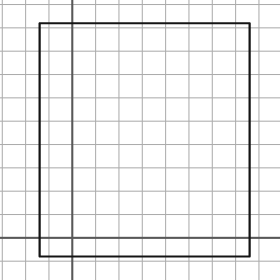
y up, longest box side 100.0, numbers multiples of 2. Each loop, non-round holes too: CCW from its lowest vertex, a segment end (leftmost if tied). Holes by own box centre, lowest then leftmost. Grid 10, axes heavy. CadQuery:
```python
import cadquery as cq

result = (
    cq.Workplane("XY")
    .moveTo(-14.0, -8.0)
    .lineTo(76.0, -8.0)
    .lineTo(76.0, 92.0)
    .lineTo(-14.0, 92.0)
    .close()
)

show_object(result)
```